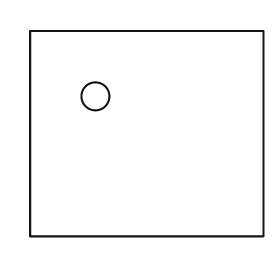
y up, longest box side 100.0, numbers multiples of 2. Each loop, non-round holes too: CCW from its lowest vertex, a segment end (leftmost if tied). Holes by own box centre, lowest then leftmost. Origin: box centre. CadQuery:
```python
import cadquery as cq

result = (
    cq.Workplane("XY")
    .moveTo(-50.0, -44.0)
    .lineTo(50.0, -44.0)
    .lineTo(50.0, 44.0)
    .lineTo(-50.0, 44.0)
    .close()
    .moveTo(-22.0, 16.0)
    .circle(6.0)
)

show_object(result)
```